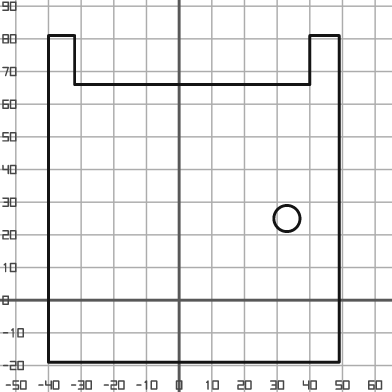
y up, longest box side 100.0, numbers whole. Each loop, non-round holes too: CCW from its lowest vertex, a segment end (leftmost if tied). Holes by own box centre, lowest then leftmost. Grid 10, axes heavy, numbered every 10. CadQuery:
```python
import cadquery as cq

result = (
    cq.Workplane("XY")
    .moveTo(-40.0, -19.0)
    .lineTo(49.0, -19.0)
    .lineTo(49.0, 81.0)
    .lineTo(40.0, 81.0)
    .lineTo(40.0, 66.0)
    .lineTo(-32.0, 66.0)
    .lineTo(-32.0, 81.0)
    .lineTo(-40.0, 81.0)
    .close()
    .moveTo(33.0, 25.0)
    .circle(4.0)
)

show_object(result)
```